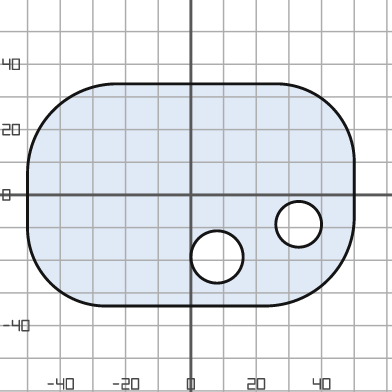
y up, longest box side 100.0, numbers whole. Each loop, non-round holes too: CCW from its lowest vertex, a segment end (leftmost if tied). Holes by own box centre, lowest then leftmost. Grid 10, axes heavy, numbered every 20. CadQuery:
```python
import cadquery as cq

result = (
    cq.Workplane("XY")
    .moveTo(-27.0, -34.0)
    .lineTo(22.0, -34.0)
    .threePointArc((42.0, -26.0), (50.0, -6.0))
    .lineTo(50.0, 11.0)
    .threePointArc((43.0, 27.0), (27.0, 34.0))
    .lineTo(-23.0, 34.0)
    .threePointArc((-42.0, 26.0), (-50.0, 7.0))
    .lineTo(-50.0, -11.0)
    .threePointArc((-43.0, -27.0), (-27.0, -34.0))
    .close()
    .moveTo(8.0, -19.0)
    .circle(8.0)
    .moveTo(33.0, -9.0)
    .circle(7.0)
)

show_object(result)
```